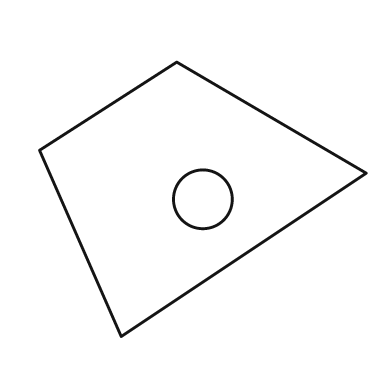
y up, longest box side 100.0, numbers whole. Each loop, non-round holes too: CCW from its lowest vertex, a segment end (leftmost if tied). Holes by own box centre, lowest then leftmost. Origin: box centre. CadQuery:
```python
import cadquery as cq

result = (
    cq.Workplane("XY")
    .moveTo(-25.0, -42.0)
    .lineTo(50.0, 8.0)
    .lineTo(-8.0, 42.0)
    .lineTo(-50.0, 15.0)
    .close()
    .moveTo(0.0, 0.0)
    .circle(9.0)
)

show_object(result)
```